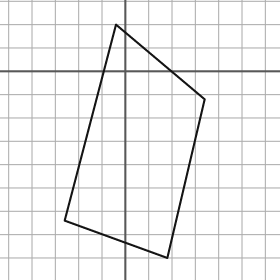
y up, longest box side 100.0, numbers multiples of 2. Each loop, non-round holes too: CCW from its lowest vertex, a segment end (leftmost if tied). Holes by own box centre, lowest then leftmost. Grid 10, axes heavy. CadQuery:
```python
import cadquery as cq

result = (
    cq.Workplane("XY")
    .moveTo(18.0, -80.0)
    .lineTo(34.0, -12.0)
    .lineTo(-4.0, 20.0)
    .lineTo(-26.0, -64.0)
    .close()
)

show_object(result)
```